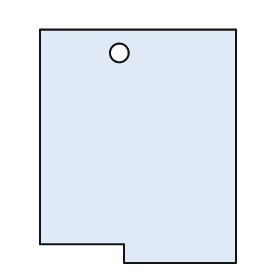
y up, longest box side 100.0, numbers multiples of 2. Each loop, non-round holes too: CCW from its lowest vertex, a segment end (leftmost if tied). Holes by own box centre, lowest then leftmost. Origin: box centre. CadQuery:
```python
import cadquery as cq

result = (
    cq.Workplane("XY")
    .moveTo(-6.0, -50.0)
    .lineTo(42.0, -50.0)
    .lineTo(42.0, 50.0)
    .lineTo(-42.0, 50.0)
    .lineTo(-42.0, -42.0)
    .lineTo(-6.0, -42.0)
    .close()
    .moveTo(-8.0, 40.0)
    .circle(4.0)
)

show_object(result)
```